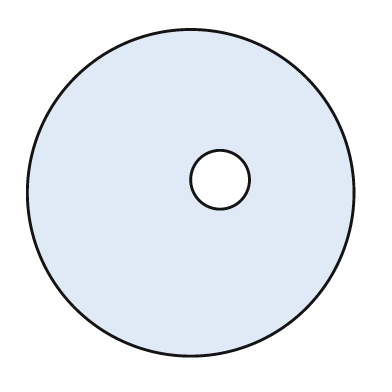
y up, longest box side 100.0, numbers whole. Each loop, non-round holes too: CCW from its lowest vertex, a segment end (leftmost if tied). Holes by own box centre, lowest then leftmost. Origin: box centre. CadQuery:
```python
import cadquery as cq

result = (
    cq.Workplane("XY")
    .moveTo(0.0, 0.0)
    .circle(50.0)
    .moveTo(9.0, 4.0)
    .circle(9.0)
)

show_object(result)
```